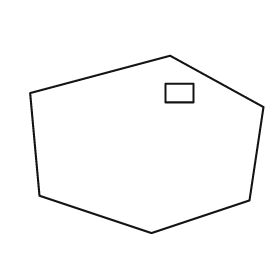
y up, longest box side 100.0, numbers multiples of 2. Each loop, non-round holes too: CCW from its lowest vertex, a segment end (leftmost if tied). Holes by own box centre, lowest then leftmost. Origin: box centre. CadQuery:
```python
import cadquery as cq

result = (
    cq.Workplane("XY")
    .moveTo(2.0, -38.0)
    .lineTo(44.0, -24.0)
    .lineTo(50.0, 16.0)
    .lineTo(10.0, 38.0)
    .lineTo(-50.0, 22.0)
    .lineTo(-46.0, -22.0)
    .close()
    .moveTo(8.0, 18.0)
    .lineTo(20.0, 18.0)
    .lineTo(20.0, 26.0)
    .lineTo(8.0, 26.0)
    .close()
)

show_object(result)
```